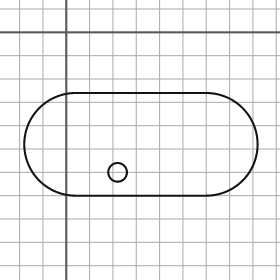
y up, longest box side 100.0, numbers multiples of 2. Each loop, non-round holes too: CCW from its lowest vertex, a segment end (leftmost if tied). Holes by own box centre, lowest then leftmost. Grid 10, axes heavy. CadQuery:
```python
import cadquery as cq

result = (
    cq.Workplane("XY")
    .moveTo(4.0, -70.0)
    .lineTo(60.0, -70.0)
    .threePointArc((82.0, -48.0), (60.0, -26.0))
    .lineTo(4.0, -26.0)
    .threePointArc((-18.0, -48.0), (4.0, -70.0))
    .close()
    .moveTo(22.0, -60.0)
    .circle(4.0)
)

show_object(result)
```